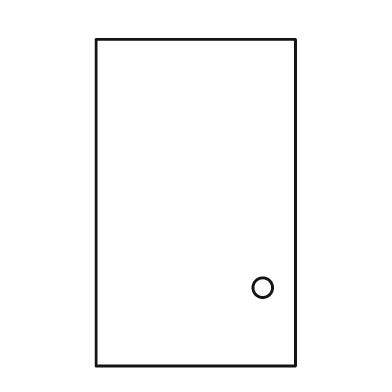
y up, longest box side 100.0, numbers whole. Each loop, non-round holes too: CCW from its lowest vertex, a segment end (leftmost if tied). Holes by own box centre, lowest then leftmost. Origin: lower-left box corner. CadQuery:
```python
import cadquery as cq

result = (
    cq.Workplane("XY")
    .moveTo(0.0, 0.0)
    .lineTo(61.0, 0.0)
    .lineTo(61.0, 100.0)
    .lineTo(0.0, 100.0)
    .close()
    .moveTo(51.0, 24.0)
    .circle(3.0)
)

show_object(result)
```